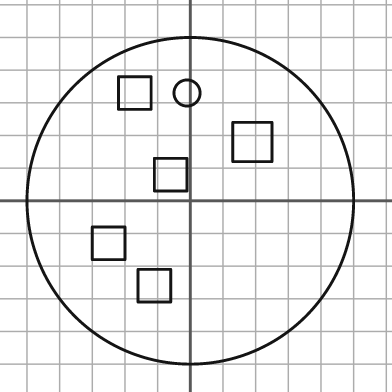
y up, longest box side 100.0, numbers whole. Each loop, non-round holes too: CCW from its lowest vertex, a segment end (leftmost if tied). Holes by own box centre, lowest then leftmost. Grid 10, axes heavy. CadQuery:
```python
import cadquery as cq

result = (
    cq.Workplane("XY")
    .moveTo(0.0, 0.0)
    .circle(50.0)
    .moveTo(-16.0, -31.0)
    .lineTo(-6.0, -31.0)
    .lineTo(-6.0, -21.0)
    .lineTo(-16.0, -21.0)
    .close()
    .moveTo(-30.0, -18.0)
    .lineTo(-20.0, -18.0)
    .lineTo(-20.0, -8.0)
    .lineTo(-30.0, -8.0)
    .close()
    .moveTo(-11.0, 3.0)
    .lineTo(-1.0, 3.0)
    .lineTo(-1.0, 13.0)
    .lineTo(-11.0, 13.0)
    .close()
    .moveTo(13.0, 12.0)
    .lineTo(25.0, 12.0)
    .lineTo(25.0, 24.0)
    .lineTo(13.0, 24.0)
    .close()
    .moveTo(-22.0, 28.0)
    .lineTo(-12.0, 28.0)
    .lineTo(-12.0, 38.0)
    .lineTo(-22.0, 38.0)
    .close()
    .moveTo(-1.0, 33.0)
    .circle(4.0)
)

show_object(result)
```